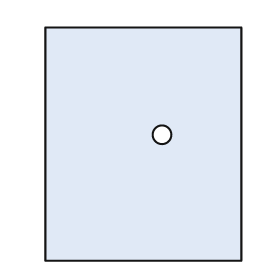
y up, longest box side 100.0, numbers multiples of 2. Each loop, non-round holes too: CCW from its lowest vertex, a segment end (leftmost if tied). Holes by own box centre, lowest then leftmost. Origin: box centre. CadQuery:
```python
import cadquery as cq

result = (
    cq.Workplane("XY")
    .moveTo(-42.0, -50.0)
    .lineTo(42.0, -50.0)
    .lineTo(42.0, 50.0)
    .lineTo(-42.0, 50.0)
    .close()
    .moveTo(8.0, 4.0)
    .circle(4.0)
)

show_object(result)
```